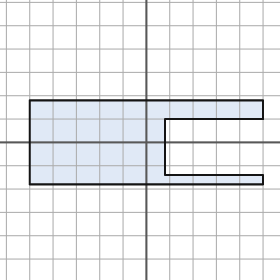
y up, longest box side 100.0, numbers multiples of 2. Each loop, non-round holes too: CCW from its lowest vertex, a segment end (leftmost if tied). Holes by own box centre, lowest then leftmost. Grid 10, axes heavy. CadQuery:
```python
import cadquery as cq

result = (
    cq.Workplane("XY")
    .moveTo(-50.0, -18.0)
    .lineTo(50.0, -18.0)
    .lineTo(50.0, -14.0)
    .lineTo(8.0, -14.0)
    .lineTo(8.0, 10.0)
    .lineTo(50.0, 10.0)
    .lineTo(50.0, 18.0)
    .lineTo(-50.0, 18.0)
    .close()
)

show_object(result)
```